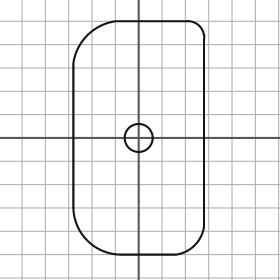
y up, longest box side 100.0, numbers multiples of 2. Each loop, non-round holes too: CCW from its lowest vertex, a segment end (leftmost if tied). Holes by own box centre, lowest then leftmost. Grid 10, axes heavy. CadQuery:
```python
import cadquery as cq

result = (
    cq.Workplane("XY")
    .moveTo(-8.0, -50.0)
    .lineTo(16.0, -50.0)
    .threePointArc((24.0, -46.0), (28.0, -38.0))
    .lineTo(28.0, 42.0)
    .threePointArc((26.0, 48.0), (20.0, 50.0))
    .lineTo(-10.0, 50.0)
    .threePointArc((-22.0, 44.0), (-28.0, 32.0))
    .lineTo(-28.0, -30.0)
    .threePointArc((-22.0, -44.0), (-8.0, -50.0))
    .close()
    .moveTo(0.0, 0.0)
    .circle(6.0)
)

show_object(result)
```